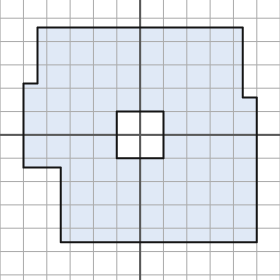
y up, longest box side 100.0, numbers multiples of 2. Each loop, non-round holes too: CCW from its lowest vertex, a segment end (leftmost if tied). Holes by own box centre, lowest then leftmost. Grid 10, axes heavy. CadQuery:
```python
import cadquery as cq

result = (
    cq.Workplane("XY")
    .moveTo(-34.0, -46.0)
    .lineTo(50.0, -46.0)
    .lineTo(50.0, 16.0)
    .lineTo(44.0, 16.0)
    .lineTo(44.0, 46.0)
    .lineTo(-44.0, 46.0)
    .lineTo(-44.0, 22.0)
    .lineTo(-50.0, 22.0)
    .lineTo(-50.0, -14.0)
    .lineTo(-34.0, -14.0)
    .close()
    .moveTo(-10.0, -10.0)
    .lineTo(10.0, -10.0)
    .lineTo(10.0, 10.0)
    .lineTo(-10.0, 10.0)
    .close()
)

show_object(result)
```